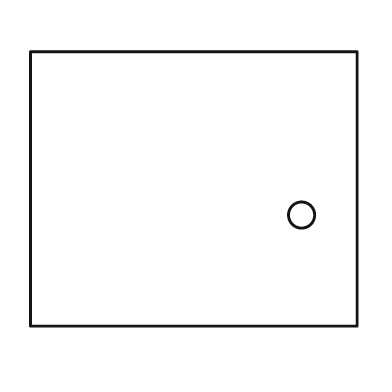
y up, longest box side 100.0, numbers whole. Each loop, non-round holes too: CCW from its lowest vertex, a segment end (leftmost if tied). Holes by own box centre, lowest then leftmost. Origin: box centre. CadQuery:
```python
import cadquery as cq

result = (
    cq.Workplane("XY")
    .moveTo(-50.0, -42.0)
    .lineTo(50.0, -42.0)
    .lineTo(50.0, 42.0)
    .lineTo(-50.0, 42.0)
    .close()
    .moveTo(33.0, -8.0)
    .circle(4.0)
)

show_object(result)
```